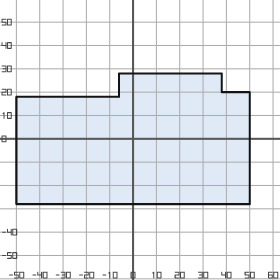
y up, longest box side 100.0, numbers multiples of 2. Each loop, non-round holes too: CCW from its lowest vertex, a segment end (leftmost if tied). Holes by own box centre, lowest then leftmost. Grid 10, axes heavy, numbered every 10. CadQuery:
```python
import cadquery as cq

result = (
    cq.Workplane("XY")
    .moveTo(-50.0, -28.0)
    .lineTo(50.0, -28.0)
    .lineTo(50.0, 20.0)
    .lineTo(38.0, 20.0)
    .lineTo(38.0, 28.0)
    .lineTo(-6.0, 28.0)
    .lineTo(-6.0, 18.0)
    .lineTo(-50.0, 18.0)
    .close()
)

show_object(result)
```